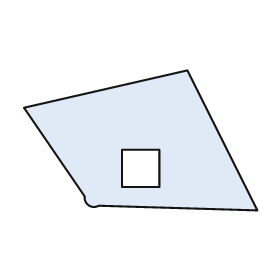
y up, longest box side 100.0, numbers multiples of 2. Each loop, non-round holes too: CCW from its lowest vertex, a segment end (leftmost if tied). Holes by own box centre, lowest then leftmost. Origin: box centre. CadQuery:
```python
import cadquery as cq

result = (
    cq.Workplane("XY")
    .moveTo(50.0, -30.0)
    .lineTo(20.0, 30.0)
    .lineTo(-50.0, 14.0)
    .lineTo(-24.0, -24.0)
    .threePointArc((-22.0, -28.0), (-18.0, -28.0))
    .close()
    .moveTo(-8.0, -20.0)
    .lineTo(8.0, -20.0)
    .lineTo(8.0, -4.0)
    .lineTo(-8.0, -4.0)
    .close()
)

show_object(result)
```